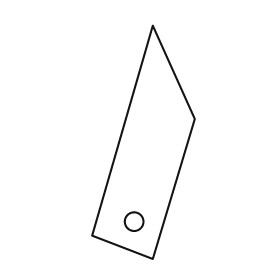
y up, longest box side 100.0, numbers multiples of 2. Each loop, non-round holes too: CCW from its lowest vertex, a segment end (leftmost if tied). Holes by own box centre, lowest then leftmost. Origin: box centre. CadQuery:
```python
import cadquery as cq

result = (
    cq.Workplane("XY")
    .moveTo(4.0, -50.0)
    .lineTo(22.0, 10.0)
    .lineTo(4.0, 50.0)
    .lineTo(-22.0, -40.0)
    .close()
    .moveTo(-4.0, -34.0)
    .circle(4.0)
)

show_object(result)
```